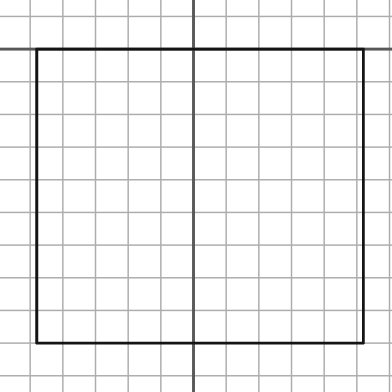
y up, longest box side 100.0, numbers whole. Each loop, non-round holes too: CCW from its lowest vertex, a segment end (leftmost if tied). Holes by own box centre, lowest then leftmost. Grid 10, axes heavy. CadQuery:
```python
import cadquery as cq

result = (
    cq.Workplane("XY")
    .moveTo(-48.0, -90.0)
    .lineTo(52.0, -90.0)
    .lineTo(52.0, 0.0)
    .lineTo(-48.0, 0.0)
    .close()
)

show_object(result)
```